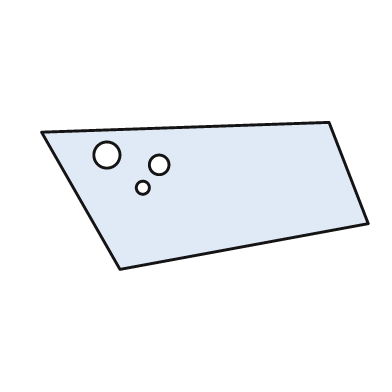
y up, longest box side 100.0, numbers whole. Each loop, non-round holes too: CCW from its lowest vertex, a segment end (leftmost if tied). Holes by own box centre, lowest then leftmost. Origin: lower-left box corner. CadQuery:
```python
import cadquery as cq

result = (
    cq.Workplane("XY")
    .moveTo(24.0, 0.0)
    .lineTo(100.0, 14.0)
    .lineTo(88.0, 45.0)
    .lineTo(0.0, 42.0)
    .close()
    .moveTo(31.0, 25.0)
    .circle(2.0)
    .moveTo(36.0, 32.0)
    .circle(3.0)
    .moveTo(20.0, 35.0)
    .circle(4.0)
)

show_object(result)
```